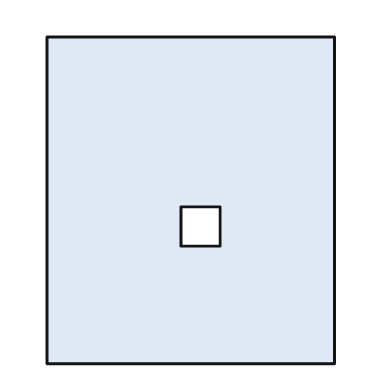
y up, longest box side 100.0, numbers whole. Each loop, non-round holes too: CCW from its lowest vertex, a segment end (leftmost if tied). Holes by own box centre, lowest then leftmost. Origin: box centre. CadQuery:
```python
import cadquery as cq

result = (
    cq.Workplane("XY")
    .moveTo(-44.0, -50.0)
    .lineTo(44.0, -50.0)
    .lineTo(44.0, 50.0)
    .lineTo(-44.0, 50.0)
    .close()
    .moveTo(-3.0, -14.0)
    .lineTo(9.0, -14.0)
    .lineTo(9.0, -2.0)
    .lineTo(-3.0, -2.0)
    .close()
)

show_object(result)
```